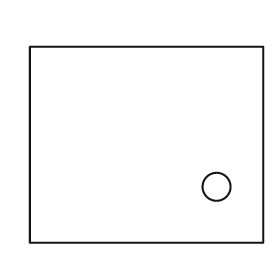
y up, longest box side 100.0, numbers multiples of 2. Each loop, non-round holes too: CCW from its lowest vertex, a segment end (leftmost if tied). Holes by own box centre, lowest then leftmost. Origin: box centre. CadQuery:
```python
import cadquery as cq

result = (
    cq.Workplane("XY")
    .moveTo(-50.0, -42.0)
    .lineTo(50.0, -42.0)
    .lineTo(50.0, 42.0)
    .lineTo(-50.0, 42.0)
    .close()
    .moveTo(30.0, -18.0)
    .circle(6.0)
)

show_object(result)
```